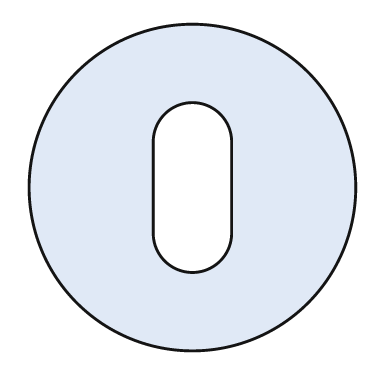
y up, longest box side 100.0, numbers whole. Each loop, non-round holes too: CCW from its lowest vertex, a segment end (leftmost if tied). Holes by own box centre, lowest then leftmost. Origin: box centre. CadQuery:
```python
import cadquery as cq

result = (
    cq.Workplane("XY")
    .moveTo(0.0, 0.0)
    .circle(50.0)
    .moveTo(-12.0, -14.0)
    .threePointArc((0.0, -26.0), (12.0, -14.0))
    .lineTo(12.0, 14.0)
    .threePointArc((0.0, 26.0), (-12.0, 14.0))
    .close()
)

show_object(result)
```